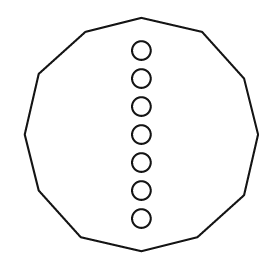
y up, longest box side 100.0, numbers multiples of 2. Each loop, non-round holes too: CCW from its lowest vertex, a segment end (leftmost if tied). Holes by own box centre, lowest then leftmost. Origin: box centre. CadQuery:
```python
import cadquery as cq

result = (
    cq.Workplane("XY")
    .moveTo(0.0, -50.0)
    .lineTo(24.0, -44.0)
    .lineTo(44.0, -26.0)
    .lineTo(50.0, 0.0)
    .lineTo(44.0, 24.0)
    .lineTo(26.0, 44.0)
    .lineTo(0.0, 50.0)
    .lineTo(-24.0, 44.0)
    .lineTo(-44.0, 26.0)
    .lineTo(-50.0, 0.0)
    .lineTo(-44.0, -24.0)
    .lineTo(-26.0, -44.0)
    .close()
    .moveTo(0.0, -36.0)
    .circle(4.0)
    .moveTo(0.0, -24.0)
    .circle(4.0)
    .moveTo(0.0, -12.0)
    .circle(4.0)
    .moveTo(0.0, 0.0)
    .circle(4.0)
    .moveTo(0.0, 12.0)
    .circle(4.0)
    .moveTo(0.0, 24.0)
    .circle(4.0)
    .moveTo(0.0, 36.0)
    .circle(4.0)
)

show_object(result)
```